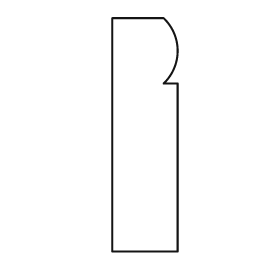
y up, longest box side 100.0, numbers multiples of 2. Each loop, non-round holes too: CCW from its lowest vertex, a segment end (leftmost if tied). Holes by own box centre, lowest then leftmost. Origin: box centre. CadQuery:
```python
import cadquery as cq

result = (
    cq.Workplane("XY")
    .moveTo(-14.0, -50.0)
    .lineTo(14.0, -50.0)
    .lineTo(14.0, 22.0)
    .lineTo(8.0, 22.0)
    .threePointArc((14.0, 36.0), (8.0, 50.0))
    .lineTo(-14.0, 50.0)
    .close()
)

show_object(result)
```